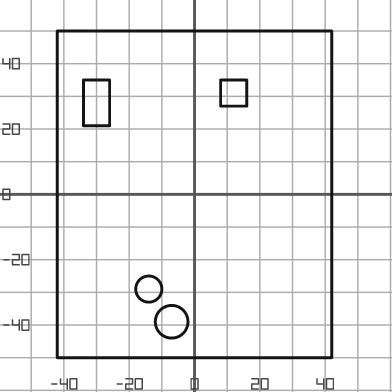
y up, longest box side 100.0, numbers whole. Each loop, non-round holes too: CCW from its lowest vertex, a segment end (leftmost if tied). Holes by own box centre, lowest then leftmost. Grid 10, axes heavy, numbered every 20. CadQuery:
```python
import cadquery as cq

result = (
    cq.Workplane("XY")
    .moveTo(-42.0, -50.0)
    .lineTo(42.0, -50.0)
    .lineTo(42.0, 50.0)
    .lineTo(-42.0, 50.0)
    .close()
    .moveTo(-7.0, -39.0)
    .circle(5.0)
    .moveTo(-14.0, -29.0)
    .circle(4.0)
    .moveTo(-34.0, 21.0)
    .lineTo(-26.0, 21.0)
    .lineTo(-26.0, 35.0)
    .lineTo(-34.0, 35.0)
    .close()
    .moveTo(8.0, 27.0)
    .lineTo(16.0, 27.0)
    .lineTo(16.0, 35.0)
    .lineTo(8.0, 35.0)
    .close()
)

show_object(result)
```